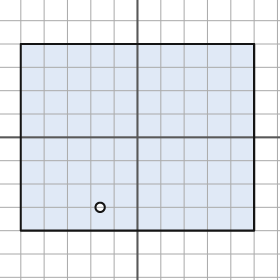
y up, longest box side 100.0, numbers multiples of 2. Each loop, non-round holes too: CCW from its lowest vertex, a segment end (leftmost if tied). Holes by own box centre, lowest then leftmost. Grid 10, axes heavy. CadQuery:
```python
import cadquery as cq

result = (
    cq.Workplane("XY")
    .moveTo(-50.0, -40.0)
    .lineTo(50.0, -40.0)
    .lineTo(50.0, 40.0)
    .lineTo(-50.0, 40.0)
    .close()
    .moveTo(-16.0, -30.0)
    .circle(2.0)
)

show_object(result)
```